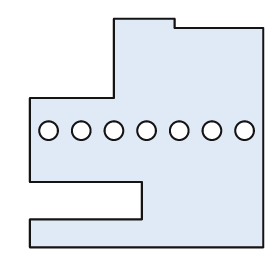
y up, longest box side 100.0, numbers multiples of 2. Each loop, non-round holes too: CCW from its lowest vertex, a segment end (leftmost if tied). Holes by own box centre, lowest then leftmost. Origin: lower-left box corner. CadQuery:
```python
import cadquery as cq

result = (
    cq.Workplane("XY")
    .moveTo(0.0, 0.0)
    .lineTo(100.0, 0.0)
    .lineTo(100.0, 94.0)
    .lineTo(62.0, 94.0)
    .lineTo(62.0, 98.0)
    .lineTo(36.0, 98.0)
    .lineTo(36.0, 64.0)
    .lineTo(0.0, 64.0)
    .lineTo(0.0, 28.0)
    .lineTo(48.0, 28.0)
    .lineTo(48.0, 12.0)
    .lineTo(0.0, 12.0)
    .close()
    .moveTo(8.0, 50.0)
    .circle(4.0)
    .moveTo(22.0, 50.0)
    .circle(4.0)
    .moveTo(36.0, 50.0)
    .circle(4.0)
    .moveTo(50.0, 50.0)
    .circle(4.0)
    .moveTo(64.0, 50.0)
    .circle(4.0)
    .moveTo(78.0, 50.0)
    .circle(4.0)
    .moveTo(92.0, 50.0)
    .circle(4.0)
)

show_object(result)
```